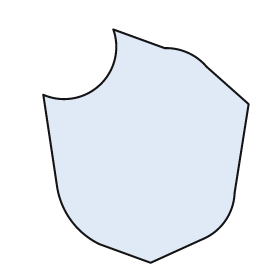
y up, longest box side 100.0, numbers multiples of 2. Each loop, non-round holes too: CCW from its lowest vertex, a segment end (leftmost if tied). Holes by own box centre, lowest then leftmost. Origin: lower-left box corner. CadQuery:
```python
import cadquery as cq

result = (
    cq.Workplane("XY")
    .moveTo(46.0, 0.0)
    .lineTo(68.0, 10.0)
    .threePointArc((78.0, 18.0), (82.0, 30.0))
    .lineTo(88.0, 68.0)
    .lineTo(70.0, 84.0)
    .threePointArc((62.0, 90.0), (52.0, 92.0))
    .lineTo(30.0, 100.0)
    .threePointArc((24.0, 76.0), (0.0, 72.0))
    .lineTo(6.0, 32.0)
    .threePointArc((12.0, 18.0), (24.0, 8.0))
    .close()
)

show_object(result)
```